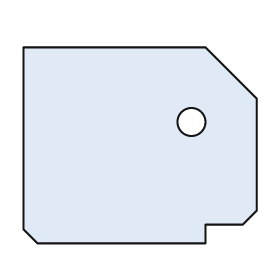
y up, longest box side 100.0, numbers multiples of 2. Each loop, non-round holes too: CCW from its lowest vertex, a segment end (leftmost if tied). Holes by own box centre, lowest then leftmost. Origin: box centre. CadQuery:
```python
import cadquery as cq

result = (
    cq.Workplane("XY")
    .moveTo(-44.0, -42.0)
    .lineTo(28.0, -42.0)
    .lineTo(28.0, -34.0)
    .lineTo(44.0, -34.0)
    .lineTo(50.0, -28.0)
    .lineTo(50.0, 20.0)
    .lineTo(28.0, 42.0)
    .lineTo(-50.0, 42.0)
    .lineTo(-50.0, -36.0)
    .close()
    .moveTo(22.0, 10.0)
    .circle(6.0)
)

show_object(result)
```